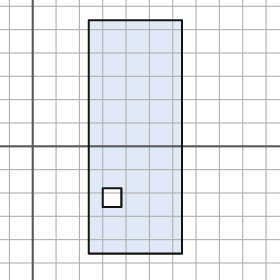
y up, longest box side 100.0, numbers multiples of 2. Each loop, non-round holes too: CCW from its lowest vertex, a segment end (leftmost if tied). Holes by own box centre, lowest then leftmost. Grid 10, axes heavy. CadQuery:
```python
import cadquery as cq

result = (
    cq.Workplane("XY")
    .moveTo(24.0, -46.0)
    .lineTo(64.0, -46.0)
    .lineTo(64.0, 54.0)
    .lineTo(24.0, 54.0)
    .close()
    .moveTo(30.0, -26.0)
    .lineTo(38.0, -26.0)
    .lineTo(38.0, -18.0)
    .lineTo(30.0, -18.0)
    .close()
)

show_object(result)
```